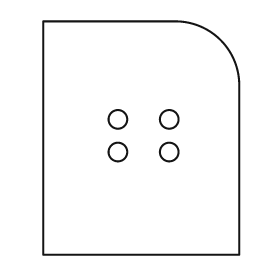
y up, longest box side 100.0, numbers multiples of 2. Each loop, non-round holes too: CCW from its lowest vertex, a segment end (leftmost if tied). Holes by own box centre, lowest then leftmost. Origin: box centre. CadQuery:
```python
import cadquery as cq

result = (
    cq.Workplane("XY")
    .moveTo(-42.0, -50.0)
    .lineTo(42.0, -50.0)
    .lineTo(42.0, 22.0)
    .threePointArc((34.0, 42.0), (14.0, 50.0))
    .lineTo(-42.0, 50.0)
    .close()
    .moveTo(-10.0, -6.0)
    .circle(4.0)
    .moveTo(12.0, -6.0)
    .circle(4.0)
    .moveTo(-10.0, 8.0)
    .circle(4.0)
    .moveTo(12.0, 8.0)
    .circle(4.0)
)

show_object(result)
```